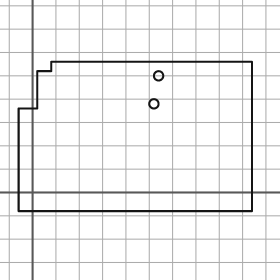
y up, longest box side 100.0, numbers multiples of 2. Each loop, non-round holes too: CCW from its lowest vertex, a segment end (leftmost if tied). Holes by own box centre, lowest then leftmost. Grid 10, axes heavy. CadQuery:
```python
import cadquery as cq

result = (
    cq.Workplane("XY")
    .moveTo(-6.0, -8.0)
    .lineTo(94.0, -8.0)
    .lineTo(94.0, 56.0)
    .lineTo(8.0, 56.0)
    .lineTo(8.0, 52.0)
    .lineTo(2.0, 52.0)
    .lineTo(2.0, 36.0)
    .lineTo(-6.0, 36.0)
    .close()
    .moveTo(52.0, 38.0)
    .circle(2.0)
    .moveTo(54.0, 50.0)
    .circle(2.0)
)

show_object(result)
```